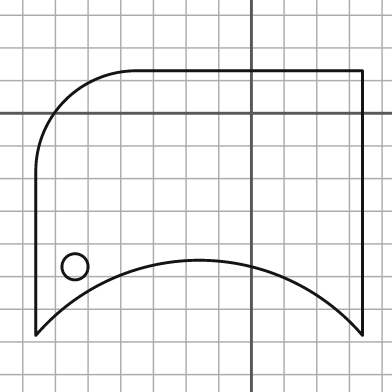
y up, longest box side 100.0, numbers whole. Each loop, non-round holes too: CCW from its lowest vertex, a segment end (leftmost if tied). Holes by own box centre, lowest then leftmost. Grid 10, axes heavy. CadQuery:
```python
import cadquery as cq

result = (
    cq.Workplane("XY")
    .moveTo(-66.0, -68.0)
    .threePointArc((-16.0, -45.0), (34.0, -68.0))
    .lineTo(34.0, 13.0)
    .lineTo(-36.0, 13.0)
    .threePointArc((-57.0, 4.0), (-66.0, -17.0))
    .close()
    .moveTo(-54.0, -47.0)
    .circle(4.0)
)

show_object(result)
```